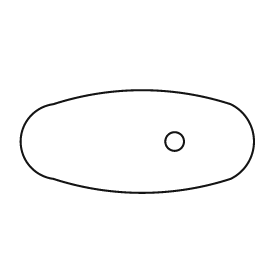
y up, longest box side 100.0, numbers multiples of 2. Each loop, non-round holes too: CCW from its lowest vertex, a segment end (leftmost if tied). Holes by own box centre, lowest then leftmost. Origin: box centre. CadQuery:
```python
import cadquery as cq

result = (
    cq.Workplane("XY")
    .moveTo(-36.0, -16.0)
    .threePointArc((2.0, -22.0), (40.0, -16.0))
    .threePointArc((50.0, 0.0), (40.0, 16.0))
    .threePointArc((2.0, 22.0), (-36.0, 16.0))
    .threePointArc((-50.0, 0.0), (-36.0, -16.0))
    .close()
    .moveTo(16.0, 0.0)
    .circle(4.0)
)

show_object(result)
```